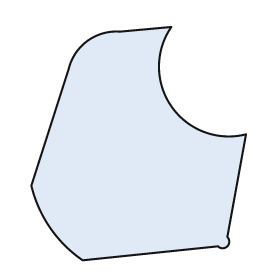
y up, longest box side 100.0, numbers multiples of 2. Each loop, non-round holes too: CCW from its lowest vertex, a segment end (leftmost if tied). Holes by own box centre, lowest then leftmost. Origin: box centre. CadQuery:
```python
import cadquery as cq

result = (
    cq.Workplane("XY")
    .moveTo(-24.0, -50.0)
    .lineTo(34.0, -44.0)
    .threePointArc((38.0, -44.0), (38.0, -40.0))
    .lineTo(46.0, 4.0)
    .threePointArc((14.0, 16.0), (14.0, 50.0))
    .lineTo(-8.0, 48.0)
    .threePointArc((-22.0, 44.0), (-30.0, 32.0))
    .lineTo(-46.0, -18.0)
    .threePointArc((-38.0, -36.0), (-24.0, -50.0))
    .close()
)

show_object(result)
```